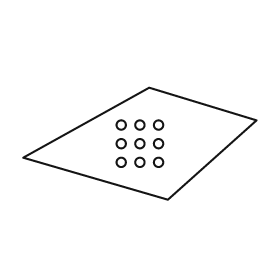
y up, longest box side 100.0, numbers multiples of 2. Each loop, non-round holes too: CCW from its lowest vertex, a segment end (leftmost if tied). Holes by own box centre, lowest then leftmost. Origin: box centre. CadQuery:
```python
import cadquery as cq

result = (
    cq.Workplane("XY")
    .moveTo(12.0, -24.0)
    .lineTo(50.0, 10.0)
    .lineTo(4.0, 24.0)
    .lineTo(-50.0, -6.0)
    .close()
    .moveTo(-8.0, -8.0)
    .circle(2.0)
    .moveTo(0.0, -8.0)
    .circle(2.0)
    .moveTo(8.0, -8.0)
    .circle(2.0)
    .moveTo(-8.0, 0.0)
    .circle(2.0)
    .moveTo(0.0, 0.0)
    .circle(2.0)
    .moveTo(8.0, 0.0)
    .circle(2.0)
    .moveTo(-8.0, 8.0)
    .circle(2.0)
    .moveTo(0.0, 8.0)
    .circle(2.0)
    .moveTo(8.0, 8.0)
    .circle(2.0)
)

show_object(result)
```